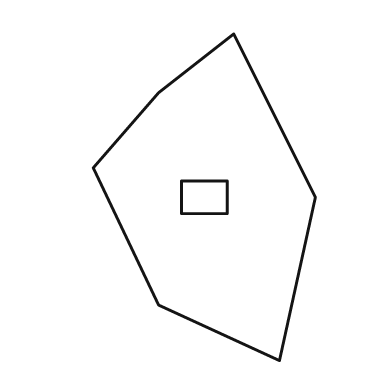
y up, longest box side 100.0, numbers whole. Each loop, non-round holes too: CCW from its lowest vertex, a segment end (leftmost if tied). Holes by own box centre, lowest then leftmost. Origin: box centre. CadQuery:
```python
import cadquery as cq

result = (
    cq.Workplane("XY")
    .moveTo(23.0, -50.0)
    .lineTo(34.0, 0.0)
    .lineTo(9.0, 50.0)
    .lineTo(-14.0, 32.0)
    .lineTo(-34.0, 9.0)
    .lineTo(-14.0, -33.0)
    .close()
    .moveTo(-7.0, -5.0)
    .lineTo(7.0, -5.0)
    .lineTo(7.0, 5.0)
    .lineTo(-7.0, 5.0)
    .close()
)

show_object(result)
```